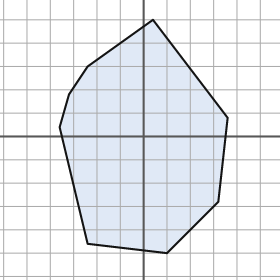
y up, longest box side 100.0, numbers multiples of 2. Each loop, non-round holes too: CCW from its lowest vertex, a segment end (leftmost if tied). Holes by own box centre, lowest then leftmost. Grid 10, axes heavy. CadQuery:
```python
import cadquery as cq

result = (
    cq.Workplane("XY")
    .moveTo(10.0, -50.0)
    .lineTo(32.0, -28.0)
    .lineTo(36.0, 8.0)
    .lineTo(4.0, 50.0)
    .lineTo(-24.0, 30.0)
    .lineTo(-32.0, 18.0)
    .lineTo(-36.0, 4.0)
    .lineTo(-24.0, -46.0)
    .close()
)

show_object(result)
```